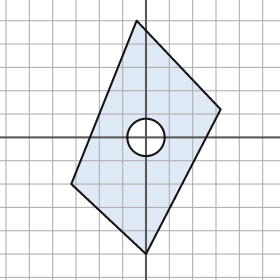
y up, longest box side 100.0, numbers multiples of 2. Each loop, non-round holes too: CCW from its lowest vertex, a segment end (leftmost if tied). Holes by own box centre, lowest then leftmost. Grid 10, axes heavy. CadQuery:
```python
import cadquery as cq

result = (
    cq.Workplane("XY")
    .moveTo(0.0, -50.0)
    .lineTo(32.0, 12.0)
    .lineTo(-4.0, 50.0)
    .lineTo(-32.0, -20.0)
    .close()
    .moveTo(0.0, 0.0)
    .circle(8.0)
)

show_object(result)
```